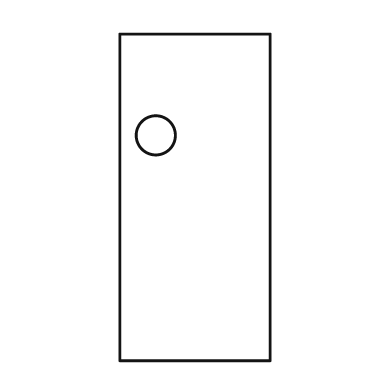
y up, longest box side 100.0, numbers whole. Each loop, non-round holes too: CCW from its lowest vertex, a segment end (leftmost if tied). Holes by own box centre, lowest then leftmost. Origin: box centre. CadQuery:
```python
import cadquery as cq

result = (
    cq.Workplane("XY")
    .moveTo(-23.0, -50.0)
    .lineTo(23.0, -50.0)
    .lineTo(23.0, 50.0)
    .lineTo(-23.0, 50.0)
    .close()
    .moveTo(-12.0, 19.0)
    .circle(6.0)
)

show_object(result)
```